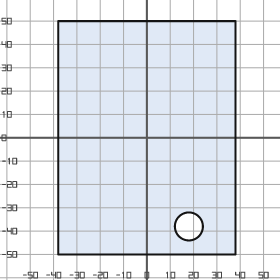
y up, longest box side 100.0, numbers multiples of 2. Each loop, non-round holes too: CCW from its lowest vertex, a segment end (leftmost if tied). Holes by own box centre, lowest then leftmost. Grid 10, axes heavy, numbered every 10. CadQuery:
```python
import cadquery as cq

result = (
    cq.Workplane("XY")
    .moveTo(-38.0, -50.0)
    .lineTo(38.0, -50.0)
    .lineTo(38.0, 50.0)
    .lineTo(-38.0, 50.0)
    .close()
    .moveTo(18.0, -38.0)
    .circle(6.0)
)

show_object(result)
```